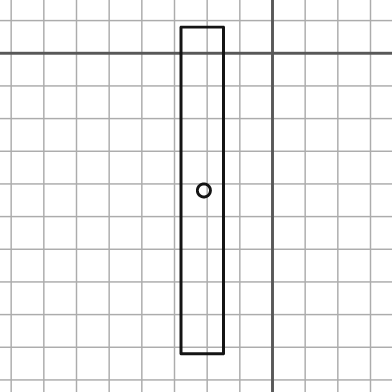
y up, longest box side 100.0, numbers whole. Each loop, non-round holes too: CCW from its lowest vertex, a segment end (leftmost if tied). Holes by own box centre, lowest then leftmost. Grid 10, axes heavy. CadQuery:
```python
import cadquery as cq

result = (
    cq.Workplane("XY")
    .moveTo(-28.0, -92.0)
    .lineTo(-15.0, -92.0)
    .lineTo(-15.0, 8.0)
    .lineTo(-28.0, 8.0)
    .close()
    .moveTo(-21.0, -42.0)
    .circle(2.0)
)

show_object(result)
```